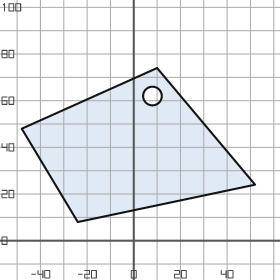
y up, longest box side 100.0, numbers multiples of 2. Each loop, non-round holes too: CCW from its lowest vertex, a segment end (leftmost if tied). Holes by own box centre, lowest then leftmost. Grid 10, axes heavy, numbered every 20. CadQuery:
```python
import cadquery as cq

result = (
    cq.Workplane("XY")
    .moveTo(-24.0, 8.0)
    .lineTo(52.0, 24.0)
    .lineTo(10.0, 74.0)
    .lineTo(-48.0, 48.0)
    .close()
    .moveTo(8.0, 62.0)
    .circle(4.0)
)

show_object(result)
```